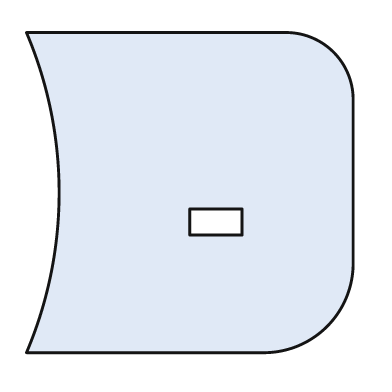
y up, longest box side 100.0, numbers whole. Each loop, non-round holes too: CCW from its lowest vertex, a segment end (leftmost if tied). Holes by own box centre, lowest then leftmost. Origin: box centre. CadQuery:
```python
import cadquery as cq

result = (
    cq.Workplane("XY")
    .moveTo(-50.0, -49.0)
    .lineTo(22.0, -49.0)
    .threePointArc((42.0, -41.0), (50.0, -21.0))
    .lineTo(50.0, 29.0)
    .threePointArc((44.0, 43.0), (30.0, 49.0))
    .lineTo(-50.0, 49.0)
    .threePointArc((-40.0, 0.0), (-50.0, -49.0))
    .close()
    .moveTo(0.0, -13.0)
    .lineTo(16.0, -13.0)
    .lineTo(16.0, -5.0)
    .lineTo(0.0, -5.0)
    .close()
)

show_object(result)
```